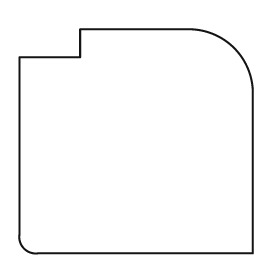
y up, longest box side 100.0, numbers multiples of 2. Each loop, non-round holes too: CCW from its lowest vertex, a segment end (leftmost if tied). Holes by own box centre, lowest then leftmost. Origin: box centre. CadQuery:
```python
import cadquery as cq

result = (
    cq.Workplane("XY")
    .moveTo(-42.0, -48.0)
    .lineTo(50.0, -48.0)
    .lineTo(50.0, 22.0)
    .threePointArc((42.0, 40.0), (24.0, 48.0))
    .lineTo(-24.0, 48.0)
    .lineTo(-24.0, 36.0)
    .lineTo(-50.0, 36.0)
    .lineTo(-50.0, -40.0)
    .threePointArc((-48.0, -46.0), (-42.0, -48.0))
    .close()
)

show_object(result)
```